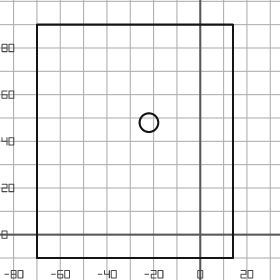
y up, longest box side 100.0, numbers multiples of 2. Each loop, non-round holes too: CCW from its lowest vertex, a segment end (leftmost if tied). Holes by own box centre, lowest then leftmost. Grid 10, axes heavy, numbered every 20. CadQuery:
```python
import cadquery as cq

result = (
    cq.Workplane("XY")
    .moveTo(-70.0, -10.0)
    .lineTo(14.0, -10.0)
    .lineTo(14.0, 90.0)
    .lineTo(-70.0, 90.0)
    .close()
    .moveTo(-22.0, 48.0)
    .circle(4.0)
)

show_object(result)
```